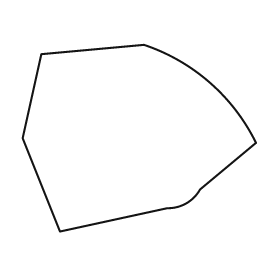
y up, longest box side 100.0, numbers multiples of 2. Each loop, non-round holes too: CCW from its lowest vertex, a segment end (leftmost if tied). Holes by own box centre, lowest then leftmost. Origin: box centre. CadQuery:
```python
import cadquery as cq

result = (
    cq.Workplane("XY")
    .moveTo(-34.0, -40.0)
    .lineTo(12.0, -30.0)
    .threePointArc((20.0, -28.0), (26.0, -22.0))
    .lineTo(50.0, -2.0)
    .threePointArc((30.0, 24.0), (2.0, 40.0))
    .lineTo(-42.0, 36.0)
    .lineTo(-50.0, 0.0)
    .close()
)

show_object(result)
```